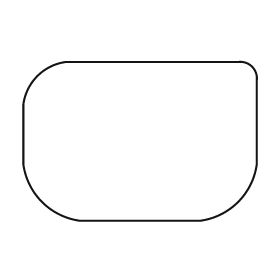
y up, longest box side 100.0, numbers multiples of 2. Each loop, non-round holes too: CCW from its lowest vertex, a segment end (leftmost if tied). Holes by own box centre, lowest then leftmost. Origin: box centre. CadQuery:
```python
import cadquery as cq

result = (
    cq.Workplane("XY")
    .moveTo(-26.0, -34.0)
    .lineTo(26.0, -34.0)
    .threePointArc((42.0, -26.0), (50.0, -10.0))
    .lineTo(50.0, 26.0)
    .threePointArc((48.0, 32.0), (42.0, 34.0))
    .lineTo(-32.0, 34.0)
    .threePointArc((-44.0, 28.0), (-50.0, 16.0))
    .lineTo(-50.0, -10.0)
    .threePointArc((-42.0, -26.0), (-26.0, -34.0))
    .close()
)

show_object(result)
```